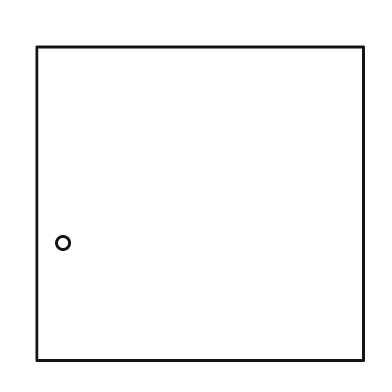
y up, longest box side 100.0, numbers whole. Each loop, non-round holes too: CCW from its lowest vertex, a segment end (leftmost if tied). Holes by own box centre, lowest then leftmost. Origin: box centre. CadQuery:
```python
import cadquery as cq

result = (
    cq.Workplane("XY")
    .moveTo(-50.0, -48.0)
    .lineTo(50.0, -48.0)
    .lineTo(50.0, 48.0)
    .lineTo(-50.0, 48.0)
    .close()
    .moveTo(-42.0, -12.0)
    .circle(2.0)
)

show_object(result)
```